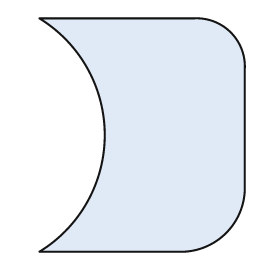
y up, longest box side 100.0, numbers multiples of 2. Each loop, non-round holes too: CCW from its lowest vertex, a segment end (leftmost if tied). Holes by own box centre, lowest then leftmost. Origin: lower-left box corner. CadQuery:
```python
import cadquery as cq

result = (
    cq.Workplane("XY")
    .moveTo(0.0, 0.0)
    .lineTo(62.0, 0.0)
    .threePointArc((80.0, 8.0), (88.0, 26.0))
    .lineTo(88.0, 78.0)
    .threePointArc((82.0, 94.0), (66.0, 100.0))
    .lineTo(0.0, 100.0)
    .threePointArc((28.0, 50.0), (0.0, 0.0))
    .close()
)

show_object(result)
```